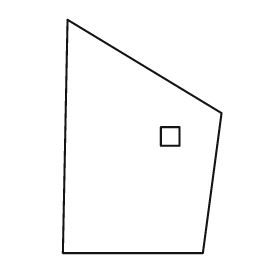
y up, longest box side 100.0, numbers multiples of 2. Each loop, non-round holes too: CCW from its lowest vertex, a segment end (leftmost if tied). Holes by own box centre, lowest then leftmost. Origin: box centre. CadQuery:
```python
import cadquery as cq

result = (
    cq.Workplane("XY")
    .moveTo(-34.0, -50.0)
    .lineTo(26.0, -50.0)
    .lineTo(34.0, 10.0)
    .lineTo(-32.0, 50.0)
    .close()
    .moveTo(8.0, -4.0)
    .lineTo(16.0, -4.0)
    .lineTo(16.0, 4.0)
    .lineTo(8.0, 4.0)
    .close()
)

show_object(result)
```